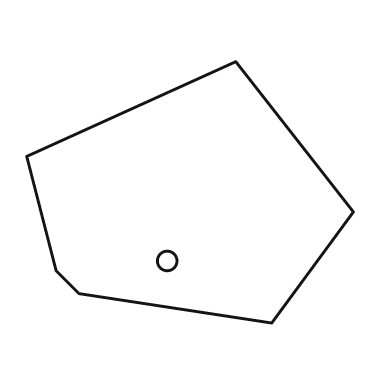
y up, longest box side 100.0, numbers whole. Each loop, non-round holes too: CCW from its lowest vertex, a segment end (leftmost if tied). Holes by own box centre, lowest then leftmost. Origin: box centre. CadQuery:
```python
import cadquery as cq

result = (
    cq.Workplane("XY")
    .moveTo(25.0, -40.0)
    .lineTo(50.0, -6.0)
    .lineTo(14.0, 40.0)
    .lineTo(-50.0, 11.0)
    .lineTo(-41.0, -24.0)
    .lineTo(-34.0, -31.0)
    .close()
    .moveTo(-7.0, -21.0)
    .circle(3.0)
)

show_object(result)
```